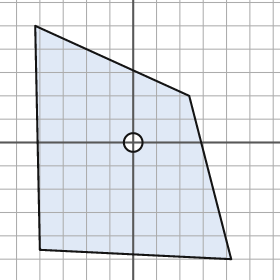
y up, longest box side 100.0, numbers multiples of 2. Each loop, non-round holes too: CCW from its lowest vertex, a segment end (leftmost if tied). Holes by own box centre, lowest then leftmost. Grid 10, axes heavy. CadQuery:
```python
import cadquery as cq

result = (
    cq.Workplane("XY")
    .moveTo(42.0, -50.0)
    .lineTo(24.0, 20.0)
    .lineTo(-42.0, 50.0)
    .lineTo(-40.0, -46.0)
    .close()
    .moveTo(0.0, 0.0)
    .circle(4.0)
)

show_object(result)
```